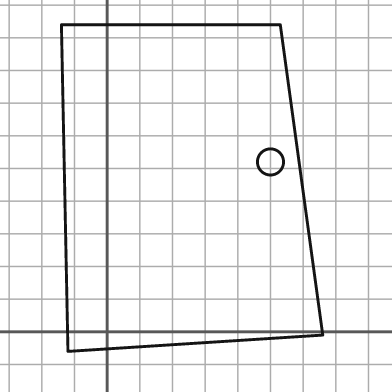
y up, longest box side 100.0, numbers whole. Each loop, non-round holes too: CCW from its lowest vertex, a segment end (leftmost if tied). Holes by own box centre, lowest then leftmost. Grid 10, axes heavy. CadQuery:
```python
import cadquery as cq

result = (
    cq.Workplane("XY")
    .moveTo(-12.0, -6.0)
    .lineTo(66.0, -1.0)
    .lineTo(53.0, 94.0)
    .lineTo(-14.0, 94.0)
    .close()
    .moveTo(50.0, 52.0)
    .circle(4.0)
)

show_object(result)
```